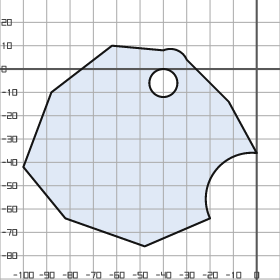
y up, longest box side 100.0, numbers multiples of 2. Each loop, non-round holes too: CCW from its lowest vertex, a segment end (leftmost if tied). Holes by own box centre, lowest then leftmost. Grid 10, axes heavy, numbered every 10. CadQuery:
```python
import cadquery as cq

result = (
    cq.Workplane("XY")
    .moveTo(-48.0, -76.0)
    .lineTo(-20.0, -64.0)
    .threePointArc((-18.0, -44.0), (0.0, -36.0))
    .lineTo(-12.0, -14.0)
    .lineTo(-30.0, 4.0)
    .threePointArc((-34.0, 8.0), (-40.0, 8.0))
    .lineTo(-62.0, 10.0)
    .lineTo(-88.0, -10.0)
    .lineTo(-100.0, -42.0)
    .lineTo(-82.0, -64.0)
    .close()
    .moveTo(-40.0, -6.0)
    .circle(6.0)
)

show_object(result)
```